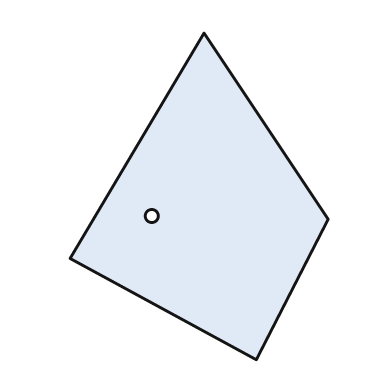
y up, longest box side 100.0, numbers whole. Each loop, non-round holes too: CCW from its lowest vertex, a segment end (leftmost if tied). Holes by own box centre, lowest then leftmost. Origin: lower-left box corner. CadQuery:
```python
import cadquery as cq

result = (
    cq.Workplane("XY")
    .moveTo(57.0, 0.0)
    .lineTo(79.0, 43.0)
    .lineTo(41.0, 100.0)
    .lineTo(0.0, 31.0)
    .close()
    .moveTo(25.0, 44.0)
    .circle(2.0)
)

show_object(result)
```